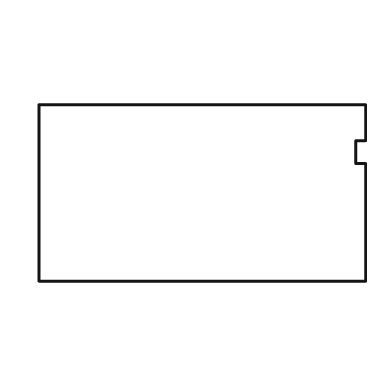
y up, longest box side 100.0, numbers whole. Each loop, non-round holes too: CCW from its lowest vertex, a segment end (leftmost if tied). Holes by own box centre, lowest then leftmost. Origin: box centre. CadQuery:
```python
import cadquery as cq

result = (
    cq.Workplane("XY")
    .moveTo(-50.0, -27.0)
    .lineTo(50.0, -27.0)
    .lineTo(50.0, 9.0)
    .lineTo(47.0, 9.0)
    .lineTo(47.0, 16.0)
    .lineTo(50.0, 16.0)
    .lineTo(50.0, 27.0)
    .lineTo(-50.0, 27.0)
    .close()
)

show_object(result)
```